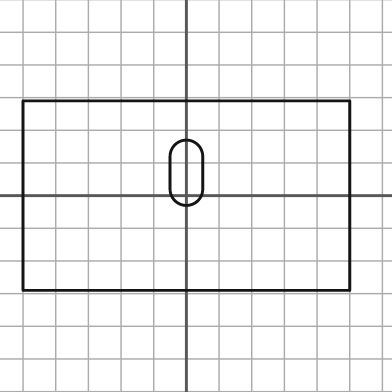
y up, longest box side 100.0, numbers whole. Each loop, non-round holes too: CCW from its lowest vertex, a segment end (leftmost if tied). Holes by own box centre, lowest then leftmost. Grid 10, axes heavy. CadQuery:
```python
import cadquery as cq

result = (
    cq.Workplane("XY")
    .moveTo(-50.0, -29.0)
    .lineTo(50.0, -29.0)
    .lineTo(50.0, 29.0)
    .lineTo(-50.0, 29.0)
    .close()
    .moveTo(-5.0, 2.0)
    .threePointArc((0.0, -3.0), (5.0, 2.0))
    .lineTo(5.0, 12.0)
    .threePointArc((0.0, 17.0), (-5.0, 12.0))
    .close()
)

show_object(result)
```